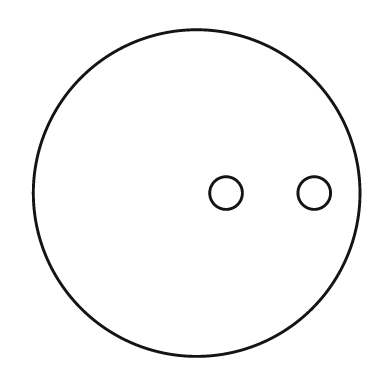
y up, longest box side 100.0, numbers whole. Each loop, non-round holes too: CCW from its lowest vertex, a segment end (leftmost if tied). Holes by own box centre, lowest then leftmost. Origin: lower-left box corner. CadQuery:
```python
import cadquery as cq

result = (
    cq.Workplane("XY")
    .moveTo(50.0, 50.0)
    .circle(50.0)
    .moveTo(59.0, 50.0)
    .circle(5.0)
    .moveTo(86.0, 50.0)
    .circle(5.0)
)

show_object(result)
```